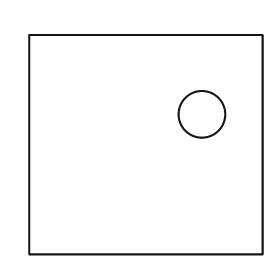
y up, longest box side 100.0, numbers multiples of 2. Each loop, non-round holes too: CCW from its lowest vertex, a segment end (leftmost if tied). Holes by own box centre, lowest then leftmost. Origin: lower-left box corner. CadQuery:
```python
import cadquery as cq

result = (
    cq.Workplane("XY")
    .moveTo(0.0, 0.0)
    .lineTo(100.0, 0.0)
    .lineTo(100.0, 94.0)
    .lineTo(0.0, 94.0)
    .close()
    .moveTo(74.0, 60.0)
    .circle(10.0)
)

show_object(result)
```